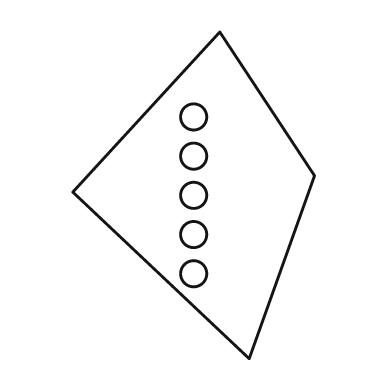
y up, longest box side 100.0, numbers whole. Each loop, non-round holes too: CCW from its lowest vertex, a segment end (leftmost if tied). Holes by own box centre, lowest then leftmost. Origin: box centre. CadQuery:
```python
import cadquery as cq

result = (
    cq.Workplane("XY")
    .moveTo(17.0, -50.0)
    .lineTo(37.0, 6.0)
    .lineTo(8.0, 50.0)
    .lineTo(-37.0, 1.0)
    .close()
    .moveTo(0.0, -24.0)
    .circle(4.0)
    .moveTo(0.0, -12.0)
    .circle(4.0)
    .moveTo(0.0, 0.0)
    .circle(4.0)
    .moveTo(0.0, 12.0)
    .circle(4.0)
    .moveTo(0.0, 24.0)
    .circle(4.0)
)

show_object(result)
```